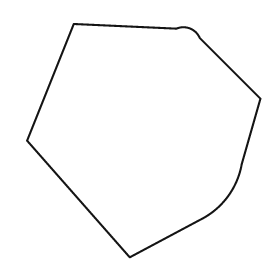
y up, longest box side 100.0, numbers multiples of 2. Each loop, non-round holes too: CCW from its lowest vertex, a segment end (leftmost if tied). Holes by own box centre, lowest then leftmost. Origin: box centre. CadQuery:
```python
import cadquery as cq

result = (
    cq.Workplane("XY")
    .moveTo(-6.0, -50.0)
    .lineTo(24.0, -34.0)
    .threePointArc((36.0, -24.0), (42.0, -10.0))
    .lineTo(50.0, 18.0)
    .lineTo(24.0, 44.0)
    .threePointArc((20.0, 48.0), (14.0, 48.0))
    .lineTo(-30.0, 50.0)
    .lineTo(-50.0, 0.0)
    .close()
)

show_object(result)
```